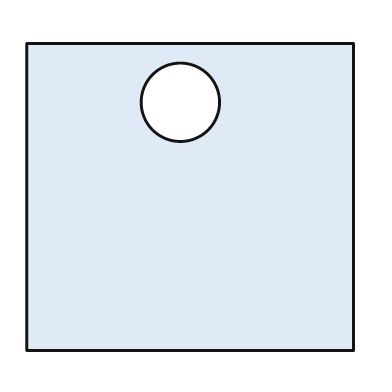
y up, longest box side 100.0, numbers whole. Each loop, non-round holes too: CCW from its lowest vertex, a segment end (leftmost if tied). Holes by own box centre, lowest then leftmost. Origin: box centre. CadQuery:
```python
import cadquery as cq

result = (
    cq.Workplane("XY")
    .moveTo(-50.0, -47.0)
    .lineTo(50.0, -47.0)
    .lineTo(50.0, 47.0)
    .lineTo(-50.0, 47.0)
    .close()
    .moveTo(-3.0, 29.0)
    .circle(12.0)
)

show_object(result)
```